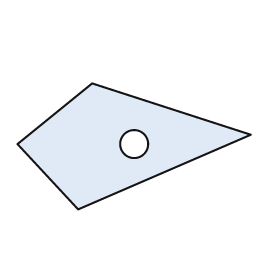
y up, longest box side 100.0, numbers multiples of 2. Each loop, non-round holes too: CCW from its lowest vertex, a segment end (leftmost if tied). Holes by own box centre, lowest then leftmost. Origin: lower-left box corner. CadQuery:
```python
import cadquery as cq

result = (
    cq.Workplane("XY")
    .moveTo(26.0, 0.0)
    .lineTo(100.0, 32.0)
    .lineTo(32.0, 54.0)
    .lineTo(0.0, 28.0)
    .close()
    .moveTo(50.0, 28.0)
    .circle(6.0)
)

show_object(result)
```